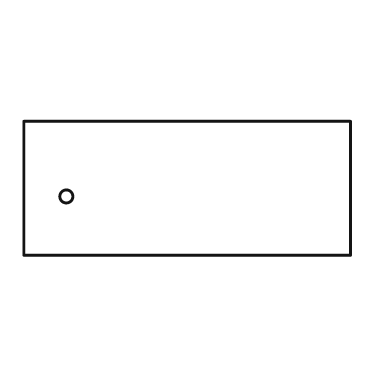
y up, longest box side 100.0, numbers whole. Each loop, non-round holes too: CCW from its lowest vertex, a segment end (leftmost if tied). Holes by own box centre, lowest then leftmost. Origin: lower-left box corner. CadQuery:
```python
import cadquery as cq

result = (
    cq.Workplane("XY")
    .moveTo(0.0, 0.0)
    .lineTo(100.0, 0.0)
    .lineTo(100.0, 41.0)
    .lineTo(0.0, 41.0)
    .close()
    .moveTo(13.0, 18.0)
    .circle(2.0)
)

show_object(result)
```